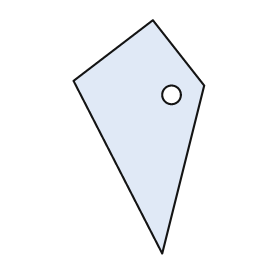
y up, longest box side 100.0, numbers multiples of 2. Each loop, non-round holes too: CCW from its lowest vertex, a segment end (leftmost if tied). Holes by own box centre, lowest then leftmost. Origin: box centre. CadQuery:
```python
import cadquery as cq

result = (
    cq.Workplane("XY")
    .moveTo(10.0, -50.0)
    .lineTo(28.0, 22.0)
    .lineTo(6.0, 50.0)
    .lineTo(-28.0, 24.0)
    .close()
    .moveTo(14.0, 18.0)
    .circle(4.0)
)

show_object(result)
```